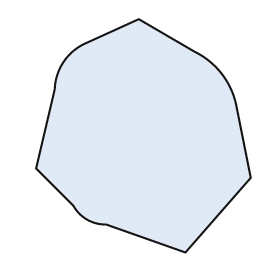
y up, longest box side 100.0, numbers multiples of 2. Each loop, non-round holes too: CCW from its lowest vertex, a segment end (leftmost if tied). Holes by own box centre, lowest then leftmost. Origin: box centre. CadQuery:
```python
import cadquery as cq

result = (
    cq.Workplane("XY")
    .moveTo(18.0, -50.0)
    .lineTo(46.0, -18.0)
    .lineTo(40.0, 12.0)
    .threePointArc((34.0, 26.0), (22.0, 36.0))
    .lineTo(-2.0, 50.0)
    .lineTo(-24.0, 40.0)
    .threePointArc((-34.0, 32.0), (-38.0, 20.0))
    .lineTo(-46.0, -14.0)
    .lineTo(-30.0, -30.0)
    .threePointArc((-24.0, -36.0), (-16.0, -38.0))
    .close()
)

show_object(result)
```